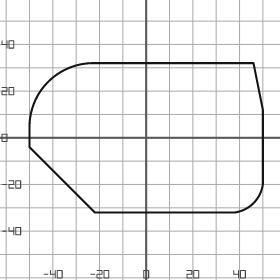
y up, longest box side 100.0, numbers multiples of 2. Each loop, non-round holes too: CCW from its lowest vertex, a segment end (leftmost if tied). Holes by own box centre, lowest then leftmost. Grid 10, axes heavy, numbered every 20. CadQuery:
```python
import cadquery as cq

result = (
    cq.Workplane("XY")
    .moveTo(-22.0, -32.0)
    .lineTo(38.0, -32.0)
    .threePointArc((46.0, -28.0), (50.0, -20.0))
    .lineTo(50.0, 12.0)
    .lineTo(46.0, 32.0)
    .lineTo(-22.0, 32.0)
    .threePointArc((-42.0, 24.0), (-50.0, 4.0))
    .lineTo(-50.0, -4.0)
    .close()
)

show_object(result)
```